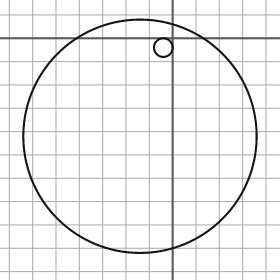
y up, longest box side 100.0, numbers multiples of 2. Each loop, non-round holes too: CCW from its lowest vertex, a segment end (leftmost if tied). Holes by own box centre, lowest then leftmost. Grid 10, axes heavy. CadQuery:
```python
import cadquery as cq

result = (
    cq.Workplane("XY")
    .moveTo(-14.0, -42.0)
    .circle(50.0)
    .moveTo(-4.0, -4.0)
    .circle(4.0)
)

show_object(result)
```